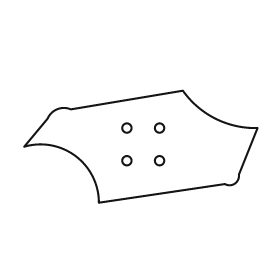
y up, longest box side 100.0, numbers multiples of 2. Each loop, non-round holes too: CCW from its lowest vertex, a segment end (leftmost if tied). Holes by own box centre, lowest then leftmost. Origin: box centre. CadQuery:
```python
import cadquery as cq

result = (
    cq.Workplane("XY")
    .moveTo(-18.0, -24.0)
    .lineTo(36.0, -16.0)
    .threePointArc((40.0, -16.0), (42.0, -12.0))
    .lineTo(50.0, 8.0)
    .threePointArc((32.0, 12.0), (18.0, 24.0))
    .lineTo(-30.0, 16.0)
    .threePointArc((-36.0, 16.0), (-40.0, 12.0))
    .lineTo(-50.0, 0.0)
    .threePointArc((-28.0, -4.0), (-18.0, -24.0))
    .close()
    .moveTo(-6.0, -6.0)
    .circle(2.0)
    .moveTo(8.0, -6.0)
    .circle(2.0)
    .moveTo(-6.0, 8.0)
    .circle(2.0)
    .moveTo(8.0, 8.0)
    .circle(2.0)
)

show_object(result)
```